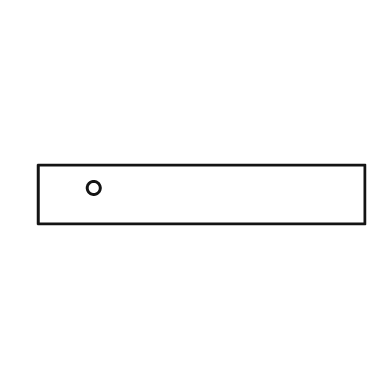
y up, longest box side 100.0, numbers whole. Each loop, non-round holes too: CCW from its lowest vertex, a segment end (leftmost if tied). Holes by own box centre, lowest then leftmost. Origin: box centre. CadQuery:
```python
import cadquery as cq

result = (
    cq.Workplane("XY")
    .moveTo(-50.0, -9.0)
    .lineTo(50.0, -9.0)
    .lineTo(50.0, 9.0)
    .lineTo(-50.0, 9.0)
    .close()
    .moveTo(-33.0, 2.0)
    .circle(2.0)
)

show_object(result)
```